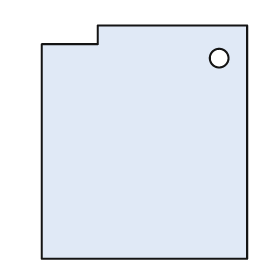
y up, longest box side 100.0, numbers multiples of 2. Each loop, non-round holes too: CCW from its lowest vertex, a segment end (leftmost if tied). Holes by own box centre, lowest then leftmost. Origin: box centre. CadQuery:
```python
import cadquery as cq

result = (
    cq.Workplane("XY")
    .moveTo(-44.0, -50.0)
    .lineTo(44.0, -50.0)
    .lineTo(44.0, 50.0)
    .lineTo(-20.0, 50.0)
    .lineTo(-20.0, 42.0)
    .lineTo(-44.0, 42.0)
    .close()
    .moveTo(32.0, 36.0)
    .circle(4.0)
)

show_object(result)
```